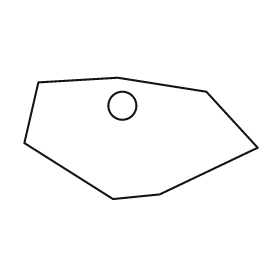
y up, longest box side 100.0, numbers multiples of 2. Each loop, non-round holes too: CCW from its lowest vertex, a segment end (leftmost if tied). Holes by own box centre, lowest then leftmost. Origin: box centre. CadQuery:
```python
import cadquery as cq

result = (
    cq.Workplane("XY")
    .moveTo(-12.0, -26.0)
    .lineTo(8.0, -24.0)
    .lineTo(50.0, -4.0)
    .lineTo(28.0, 20.0)
    .lineTo(-10.0, 26.0)
    .lineTo(-44.0, 24.0)
    .lineTo(-50.0, -2.0)
    .close()
    .moveTo(-8.0, 14.0)
    .circle(6.0)
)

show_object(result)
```